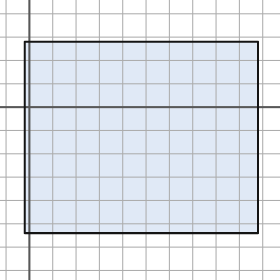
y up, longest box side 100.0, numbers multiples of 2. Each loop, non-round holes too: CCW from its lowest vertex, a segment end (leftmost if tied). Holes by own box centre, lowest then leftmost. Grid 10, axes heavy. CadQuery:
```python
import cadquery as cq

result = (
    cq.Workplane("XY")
    .moveTo(-2.0, -54.0)
    .lineTo(98.0, -54.0)
    .lineTo(98.0, 28.0)
    .lineTo(-2.0, 28.0)
    .close()
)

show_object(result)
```